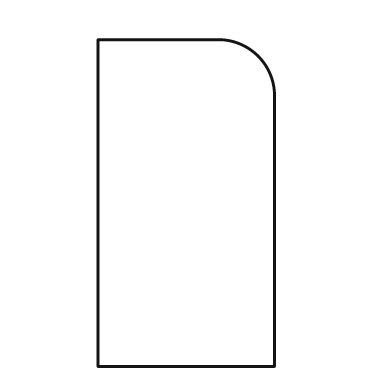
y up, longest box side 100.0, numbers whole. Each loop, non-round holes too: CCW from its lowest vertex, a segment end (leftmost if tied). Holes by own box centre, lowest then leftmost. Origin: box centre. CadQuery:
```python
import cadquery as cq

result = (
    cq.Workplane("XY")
    .moveTo(-27.0, -50.0)
    .lineTo(27.0, -50.0)
    .lineTo(27.0, 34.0)
    .threePointArc((22.0, 45.0), (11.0, 50.0))
    .lineTo(-27.0, 50.0)
    .close()
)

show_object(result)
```